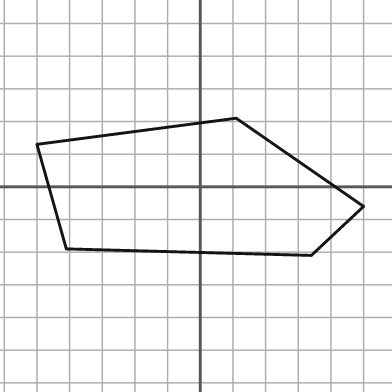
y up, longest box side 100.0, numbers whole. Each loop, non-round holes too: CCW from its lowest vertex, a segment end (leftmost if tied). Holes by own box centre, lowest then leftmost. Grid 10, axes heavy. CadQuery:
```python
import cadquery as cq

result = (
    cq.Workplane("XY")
    .moveTo(34.0, -21.0)
    .lineTo(50.0, -6.0)
    .lineTo(11.0, 21.0)
    .lineTo(-50.0, 13.0)
    .lineTo(-41.0, -19.0)
    .close()
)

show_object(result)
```